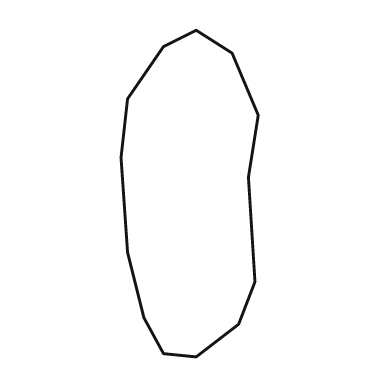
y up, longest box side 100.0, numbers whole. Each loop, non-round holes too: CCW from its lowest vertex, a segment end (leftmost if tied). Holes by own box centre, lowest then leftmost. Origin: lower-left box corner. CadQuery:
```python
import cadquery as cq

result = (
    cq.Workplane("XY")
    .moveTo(23.0, 0.0)
    .lineTo(36.0, 10.0)
    .lineTo(41.0, 23.0)
    .lineTo(39.0, 55.0)
    .lineTo(42.0, 74.0)
    .lineTo(34.0, 93.0)
    .lineTo(23.0, 100.0)
    .lineTo(13.0, 95.0)
    .lineTo(2.0, 79.0)
    .lineTo(0.0, 61.0)
    .lineTo(2.0, 32.0)
    .lineTo(7.0, 12.0)
    .lineTo(13.0, 1.0)
    .close()
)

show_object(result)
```